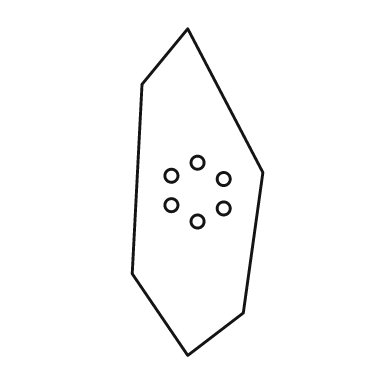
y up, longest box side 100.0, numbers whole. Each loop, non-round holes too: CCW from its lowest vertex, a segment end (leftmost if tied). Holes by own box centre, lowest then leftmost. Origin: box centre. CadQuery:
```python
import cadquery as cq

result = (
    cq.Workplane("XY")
    .moveTo(-3.0, -50.0)
    .lineTo(14.0, -37.0)
    .lineTo(20.0, 6.0)
    .lineTo(-3.0, 50.0)
    .lineTo(-17.0, 33.0)
    .lineTo(-20.0, -25.0)
    .close()
    .moveTo(0.0, -9.0)
    .circle(2.0)
    .moveTo(8.0, -5.0)
    .circle(2.0)
    .moveTo(-8.0, -4.0)
    .circle(2.0)
    .moveTo(8.0, 4.0)
    .circle(2.0)
    .moveTo(-8.0, 5.0)
    .circle(2.0)
    .moveTo(0.0, 9.0)
    .circle(2.0)
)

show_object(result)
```